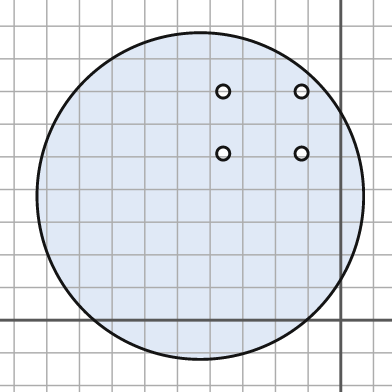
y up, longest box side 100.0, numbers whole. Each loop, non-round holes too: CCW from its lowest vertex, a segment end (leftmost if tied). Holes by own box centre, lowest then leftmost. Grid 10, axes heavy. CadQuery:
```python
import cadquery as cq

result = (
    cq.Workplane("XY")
    .moveTo(-43.0, 38.0)
    .circle(50.0)
    .moveTo(-36.0, 51.0)
    .circle(2.0)
    .moveTo(-12.0, 51.0)
    .circle(2.0)
    .moveTo(-36.0, 70.0)
    .circle(2.0)
    .moveTo(-12.0, 70.0)
    .circle(2.0)
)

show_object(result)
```